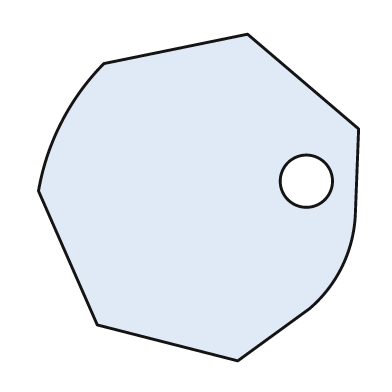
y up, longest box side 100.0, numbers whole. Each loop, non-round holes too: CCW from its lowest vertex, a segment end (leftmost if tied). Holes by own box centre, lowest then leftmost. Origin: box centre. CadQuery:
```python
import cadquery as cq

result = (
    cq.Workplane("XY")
    .moveTo(12.0, -50.0)
    .lineTo(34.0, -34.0)
    .threePointArc((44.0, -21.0), (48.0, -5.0))
    .lineTo(49.0, 21.0)
    .lineTo(15.0, 50.0)
    .lineTo(-29.0, 41.0)
    .threePointArc((-42.0, 23.0), (-49.0, 2.0))
    .lineTo(-31.0, -39.0)
    .close()
    .moveTo(33.0, 5.0)
    .circle(8.0)
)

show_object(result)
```